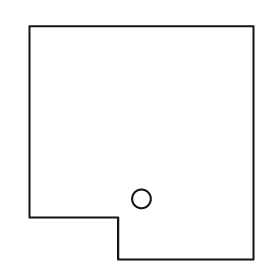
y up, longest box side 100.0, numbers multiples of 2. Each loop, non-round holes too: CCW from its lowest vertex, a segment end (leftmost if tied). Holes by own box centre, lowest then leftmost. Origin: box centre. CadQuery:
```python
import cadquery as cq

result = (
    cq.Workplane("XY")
    .moveTo(-10.0, -50.0)
    .lineTo(48.0, -50.0)
    .lineTo(48.0, 50.0)
    .lineTo(-48.0, 50.0)
    .lineTo(-48.0, -32.0)
    .lineTo(-10.0, -32.0)
    .close()
    .moveTo(0.0, -24.0)
    .circle(4.0)
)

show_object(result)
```